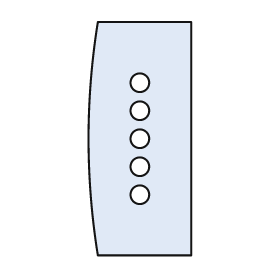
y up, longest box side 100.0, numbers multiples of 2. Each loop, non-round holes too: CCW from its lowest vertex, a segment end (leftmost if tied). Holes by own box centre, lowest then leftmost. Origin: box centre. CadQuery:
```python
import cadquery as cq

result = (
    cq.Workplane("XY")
    .moveTo(-18.0, -50.0)
    .lineTo(22.0, -50.0)
    .lineTo(22.0, 50.0)
    .lineTo(-18.0, 50.0)
    .threePointArc((-22.0, 0.0), (-18.0, -50.0))
    .close()
    .moveTo(0.0, -24.0)
    .circle(4.0)
    .moveTo(0.0, -12.0)
    .circle(4.0)
    .moveTo(0.0, 0.0)
    .circle(4.0)
    .moveTo(0.0, 12.0)
    .circle(4.0)
    .moveTo(0.0, 24.0)
    .circle(4.0)
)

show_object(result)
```